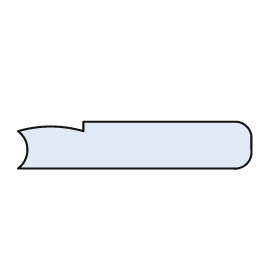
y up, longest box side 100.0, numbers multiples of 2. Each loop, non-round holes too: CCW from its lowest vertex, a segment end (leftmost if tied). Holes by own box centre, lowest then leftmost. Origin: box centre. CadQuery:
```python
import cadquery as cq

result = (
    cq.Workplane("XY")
    .moveTo(-50.0, -10.0)
    .lineTo(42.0, -10.0)
    .threePointArc((48.0, -8.0), (50.0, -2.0))
    .lineTo(50.0, 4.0)
    .threePointArc((48.0, 8.0), (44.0, 10.0))
    .lineTo(-22.0, 10.0)
    .lineTo(-22.0, 6.0)
    .threePointArc((-36.0, 8.0), (-50.0, 6.0))
    .threePointArc((-46.0, -2.0), (-50.0, -10.0))
    .close()
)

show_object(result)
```